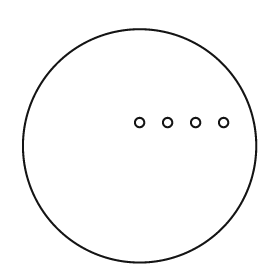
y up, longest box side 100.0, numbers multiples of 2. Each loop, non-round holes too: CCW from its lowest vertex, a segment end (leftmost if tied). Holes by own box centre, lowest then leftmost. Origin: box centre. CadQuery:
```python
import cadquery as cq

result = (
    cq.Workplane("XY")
    .moveTo(0.0, 0.0)
    .circle(50.0)
    .moveTo(0.0, 10.0)
    .circle(2.0)
    .moveTo(12.0, 10.0)
    .circle(2.0)
    .moveTo(24.0, 10.0)
    .circle(2.0)
    .moveTo(36.0, 10.0)
    .circle(2.0)
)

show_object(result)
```